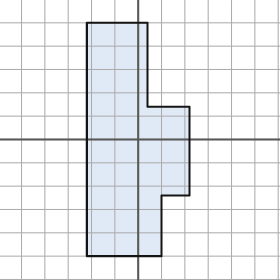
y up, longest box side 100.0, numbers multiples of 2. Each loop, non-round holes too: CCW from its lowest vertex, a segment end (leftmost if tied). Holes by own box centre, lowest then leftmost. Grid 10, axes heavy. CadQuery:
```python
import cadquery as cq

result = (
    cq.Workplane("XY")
    .moveTo(-22.0, -50.0)
    .lineTo(10.0, -50.0)
    .lineTo(10.0, -24.0)
    .lineTo(22.0, -24.0)
    .lineTo(22.0, 14.0)
    .lineTo(4.0, 14.0)
    .lineTo(4.0, 50.0)
    .lineTo(-22.0, 50.0)
    .close()
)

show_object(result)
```